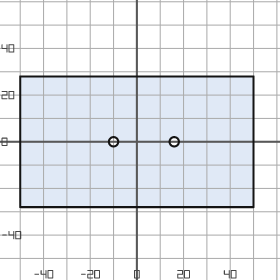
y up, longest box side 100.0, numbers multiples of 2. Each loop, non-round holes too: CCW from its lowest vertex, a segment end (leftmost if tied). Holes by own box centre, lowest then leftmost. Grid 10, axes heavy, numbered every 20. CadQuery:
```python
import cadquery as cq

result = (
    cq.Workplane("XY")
    .moveTo(-50.0, -28.0)
    .lineTo(50.0, -28.0)
    .lineTo(50.0, 28.0)
    .lineTo(-50.0, 28.0)
    .close()
    .moveTo(-10.0, 0.0)
    .circle(2.0)
    .moveTo(16.0, 0.0)
    .circle(2.0)
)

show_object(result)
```